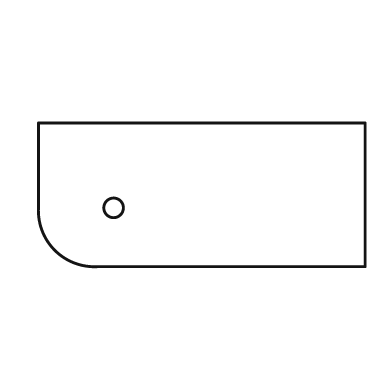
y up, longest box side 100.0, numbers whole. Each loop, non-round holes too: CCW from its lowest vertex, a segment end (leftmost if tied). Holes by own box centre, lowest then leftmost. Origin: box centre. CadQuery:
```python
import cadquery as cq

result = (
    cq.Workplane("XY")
    .moveTo(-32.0, -22.0)
    .lineTo(50.0, -22.0)
    .lineTo(50.0, 22.0)
    .lineTo(-50.0, 22.0)
    .lineTo(-50.0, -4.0)
    .threePointArc((-45.0, -17.0), (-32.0, -22.0))
    .close()
    .moveTo(-27.0, -4.0)
    .circle(3.0)
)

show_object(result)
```